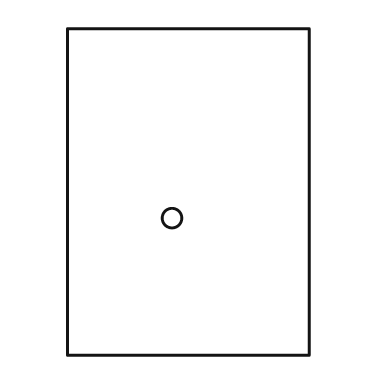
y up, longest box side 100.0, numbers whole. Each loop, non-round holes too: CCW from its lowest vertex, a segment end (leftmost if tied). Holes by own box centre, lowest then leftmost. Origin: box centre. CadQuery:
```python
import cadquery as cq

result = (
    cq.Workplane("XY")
    .moveTo(-37.0, -50.0)
    .lineTo(37.0, -50.0)
    .lineTo(37.0, 50.0)
    .lineTo(-37.0, 50.0)
    .close()
    .moveTo(-5.0, -8.0)
    .circle(3.0)
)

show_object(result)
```